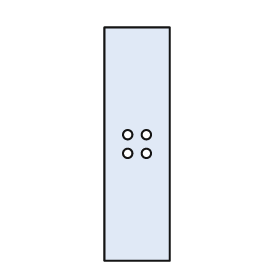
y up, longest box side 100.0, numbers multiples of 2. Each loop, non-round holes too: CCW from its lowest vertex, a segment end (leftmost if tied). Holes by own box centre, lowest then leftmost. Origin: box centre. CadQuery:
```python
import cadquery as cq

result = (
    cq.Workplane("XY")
    .moveTo(-14.0, -50.0)
    .lineTo(14.0, -50.0)
    .lineTo(14.0, 50.0)
    .lineTo(-14.0, 50.0)
    .close()
    .moveTo(-4.0, -4.0)
    .circle(2.0)
    .moveTo(4.0, -4.0)
    .circle(2.0)
    .moveTo(-4.0, 4.0)
    .circle(2.0)
    .moveTo(4.0, 4.0)
    .circle(2.0)
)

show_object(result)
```